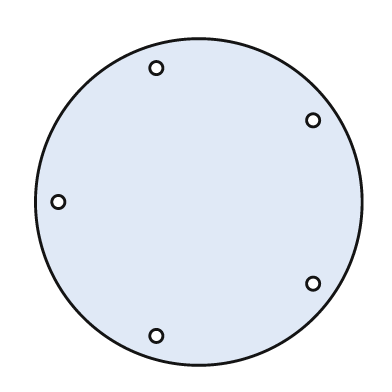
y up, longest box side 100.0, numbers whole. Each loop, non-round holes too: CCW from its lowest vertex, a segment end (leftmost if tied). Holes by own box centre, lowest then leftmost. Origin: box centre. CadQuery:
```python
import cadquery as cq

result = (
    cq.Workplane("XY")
    .moveTo(0.0, 0.0)
    .circle(50.0)
    .moveTo(-13.0, -41.0)
    .circle(2.0)
    .moveTo(35.0, -25.0)
    .circle(2.0)
    .moveTo(-43.0, 0.0)
    .circle(2.0)
    .moveTo(35.0, 25.0)
    .circle(2.0)
    .moveTo(-13.0, 41.0)
    .circle(2.0)
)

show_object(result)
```